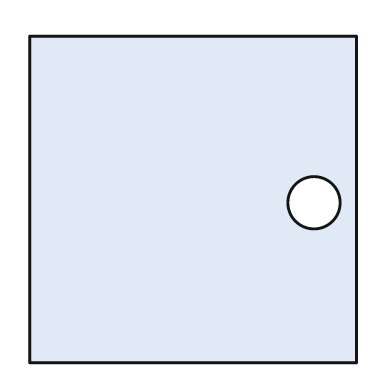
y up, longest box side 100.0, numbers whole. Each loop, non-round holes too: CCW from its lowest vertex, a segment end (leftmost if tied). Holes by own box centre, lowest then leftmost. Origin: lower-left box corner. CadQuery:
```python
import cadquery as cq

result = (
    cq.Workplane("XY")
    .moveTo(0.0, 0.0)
    .lineTo(100.0, 0.0)
    .lineTo(100.0, 100.0)
    .lineTo(0.0, 100.0)
    .close()
    .moveTo(87.0, 49.0)
    .circle(8.0)
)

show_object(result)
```